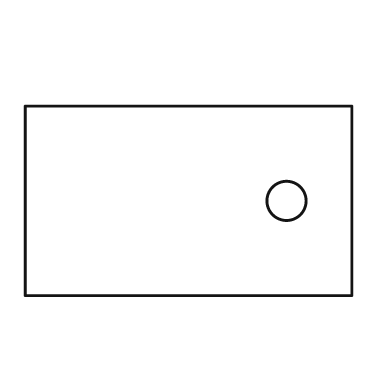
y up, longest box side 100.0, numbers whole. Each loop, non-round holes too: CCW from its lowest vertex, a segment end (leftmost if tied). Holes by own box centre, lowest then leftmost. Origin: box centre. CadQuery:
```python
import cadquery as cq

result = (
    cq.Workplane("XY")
    .moveTo(-50.0, -29.0)
    .lineTo(50.0, -29.0)
    .lineTo(50.0, 29.0)
    .lineTo(-50.0, 29.0)
    .close()
    .moveTo(30.0, 0.0)
    .circle(6.0)
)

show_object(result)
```